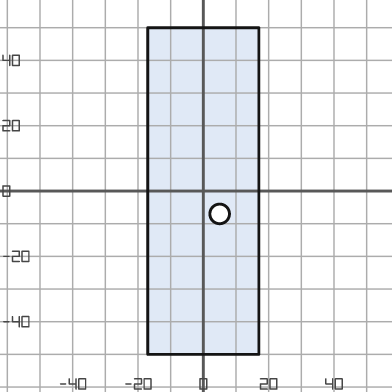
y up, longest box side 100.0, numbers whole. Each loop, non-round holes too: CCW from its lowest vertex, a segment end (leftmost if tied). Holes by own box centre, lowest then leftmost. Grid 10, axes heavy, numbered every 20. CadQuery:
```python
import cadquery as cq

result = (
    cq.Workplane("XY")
    .moveTo(-17.0, -50.0)
    .lineTo(17.0, -50.0)
    .lineTo(17.0, 50.0)
    .lineTo(-17.0, 50.0)
    .close()
    .moveTo(5.0, -7.0)
    .circle(3.0)
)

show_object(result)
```